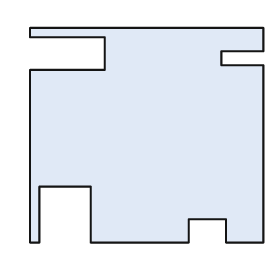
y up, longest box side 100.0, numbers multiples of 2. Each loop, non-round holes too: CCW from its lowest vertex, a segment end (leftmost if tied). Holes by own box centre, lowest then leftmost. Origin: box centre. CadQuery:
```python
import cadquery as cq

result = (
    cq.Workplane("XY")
    .moveTo(-50.0, -46.0)
    .lineTo(-46.0, -46.0)
    .lineTo(-46.0, -22.0)
    .lineTo(-24.0, -22.0)
    .lineTo(-24.0, -46.0)
    .lineTo(18.0, -46.0)
    .lineTo(18.0, -36.0)
    .lineTo(34.0, -36.0)
    .lineTo(34.0, -46.0)
    .lineTo(50.0, -46.0)
    .lineTo(50.0, 30.0)
    .lineTo(32.0, 30.0)
    .lineTo(32.0, 36.0)
    .lineTo(50.0, 36.0)
    .lineTo(50.0, 46.0)
    .lineTo(-50.0, 46.0)
    .lineTo(-50.0, 42.0)
    .lineTo(-18.0, 42.0)
    .lineTo(-18.0, 28.0)
    .lineTo(-50.0, 28.0)
    .close()
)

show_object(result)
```